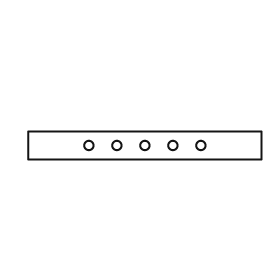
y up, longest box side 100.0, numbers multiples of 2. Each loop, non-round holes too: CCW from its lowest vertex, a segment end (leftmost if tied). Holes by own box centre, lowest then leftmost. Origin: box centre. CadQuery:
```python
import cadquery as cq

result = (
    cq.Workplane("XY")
    .moveTo(-50.0, -6.0)
    .lineTo(50.0, -6.0)
    .lineTo(50.0, 6.0)
    .lineTo(-50.0, 6.0)
    .close()
    .moveTo(-24.0, 0.0)
    .circle(2.0)
    .moveTo(-12.0, 0.0)
    .circle(2.0)
    .moveTo(0.0, 0.0)
    .circle(2.0)
    .moveTo(12.0, 0.0)
    .circle(2.0)
    .moveTo(24.0, 0.0)
    .circle(2.0)
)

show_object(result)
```